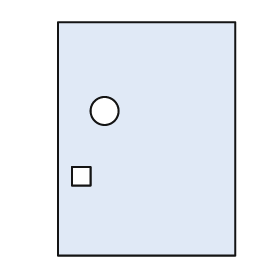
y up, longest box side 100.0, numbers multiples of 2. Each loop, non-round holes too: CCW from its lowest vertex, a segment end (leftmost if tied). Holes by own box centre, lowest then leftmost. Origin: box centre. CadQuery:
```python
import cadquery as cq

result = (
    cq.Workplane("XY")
    .moveTo(-38.0, -50.0)
    .lineTo(38.0, -50.0)
    .lineTo(38.0, 50.0)
    .lineTo(-38.0, 50.0)
    .close()
    .moveTo(-32.0, -20.0)
    .lineTo(-24.0, -20.0)
    .lineTo(-24.0, -12.0)
    .lineTo(-32.0, -12.0)
    .close()
    .moveTo(-18.0, 12.0)
    .circle(6.0)
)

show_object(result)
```